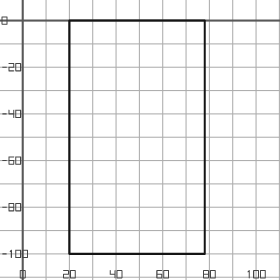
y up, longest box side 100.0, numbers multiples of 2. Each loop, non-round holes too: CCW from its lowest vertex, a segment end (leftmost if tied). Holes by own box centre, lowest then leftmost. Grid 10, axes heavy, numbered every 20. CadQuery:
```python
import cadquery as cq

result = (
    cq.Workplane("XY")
    .moveTo(20.0, -100.0)
    .lineTo(78.0, -100.0)
    .lineTo(78.0, 0.0)
    .lineTo(20.0, 0.0)
    .close()
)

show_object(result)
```